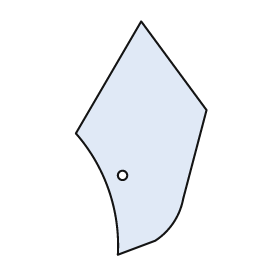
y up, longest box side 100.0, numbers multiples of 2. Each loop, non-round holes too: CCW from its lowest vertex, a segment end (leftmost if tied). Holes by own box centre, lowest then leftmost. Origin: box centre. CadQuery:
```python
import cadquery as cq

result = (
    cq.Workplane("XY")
    .moveTo(-10.0, -50.0)
    .lineTo(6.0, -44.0)
    .threePointArc((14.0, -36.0), (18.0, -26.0))
    .lineTo(28.0, 12.0)
    .lineTo(0.0, 50.0)
    .lineTo(-28.0, 2.0)
    .threePointArc((-14.0, -22.0), (-10.0, -50.0))
    .close()
    .moveTo(-8.0, -16.0)
    .circle(2.0)
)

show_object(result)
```